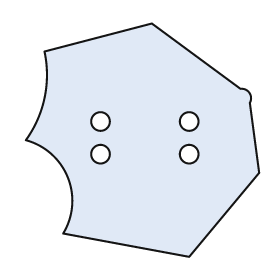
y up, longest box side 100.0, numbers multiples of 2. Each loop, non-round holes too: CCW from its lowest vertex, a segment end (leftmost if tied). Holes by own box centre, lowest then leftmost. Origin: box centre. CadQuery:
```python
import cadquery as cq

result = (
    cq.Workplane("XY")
    .moveTo(20.0, -50.0)
    .lineTo(50.0, -14.0)
    .lineTo(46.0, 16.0)
    .threePointArc((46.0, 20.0), (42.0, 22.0))
    .lineTo(4.0, 50.0)
    .lineTo(-42.0, 38.0)
    .threePointArc((-42.0, 18.0), (-50.0, 0.0))
    .threePointArc((-32.0, -16.0), (-34.0, -40.0))
    .close()
    .moveTo(-18.0, -6.0)
    .circle(4.0)
    .moveTo(20.0, -6.0)
    .circle(4.0)
    .moveTo(-18.0, 8.0)
    .circle(4.0)
    .moveTo(20.0, 8.0)
    .circle(4.0)
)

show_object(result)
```